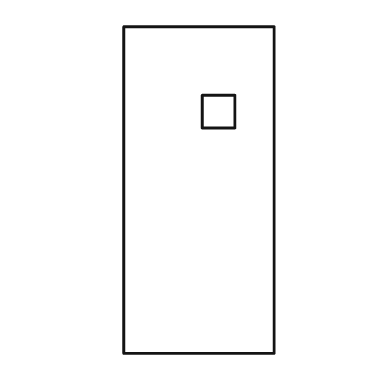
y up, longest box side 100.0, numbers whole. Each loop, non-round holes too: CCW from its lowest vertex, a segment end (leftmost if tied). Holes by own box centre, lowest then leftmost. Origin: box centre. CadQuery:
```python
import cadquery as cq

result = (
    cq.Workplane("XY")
    .moveTo(-23.0, -50.0)
    .lineTo(23.0, -50.0)
    .lineTo(23.0, 50.0)
    .lineTo(-23.0, 50.0)
    .close()
    .moveTo(1.0, 19.0)
    .lineTo(11.0, 19.0)
    .lineTo(11.0, 29.0)
    .lineTo(1.0, 29.0)
    .close()
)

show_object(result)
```